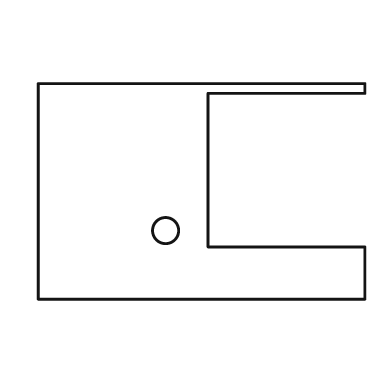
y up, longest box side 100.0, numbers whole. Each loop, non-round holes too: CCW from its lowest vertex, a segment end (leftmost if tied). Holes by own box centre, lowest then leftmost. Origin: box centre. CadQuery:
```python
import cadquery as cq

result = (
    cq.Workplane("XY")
    .moveTo(-50.0, -33.0)
    .lineTo(50.0, -33.0)
    .lineTo(50.0, -17.0)
    .lineTo(2.0, -17.0)
    .lineTo(2.0, 30.0)
    .lineTo(50.0, 30.0)
    .lineTo(50.0, 33.0)
    .lineTo(-50.0, 33.0)
    .close()
    .moveTo(-11.0, -12.0)
    .circle(4.0)
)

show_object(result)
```